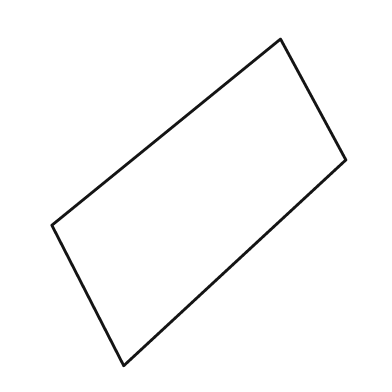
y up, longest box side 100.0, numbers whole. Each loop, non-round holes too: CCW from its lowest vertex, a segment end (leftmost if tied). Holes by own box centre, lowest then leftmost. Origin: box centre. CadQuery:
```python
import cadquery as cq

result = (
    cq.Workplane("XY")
    .moveTo(-23.0, -50.0)
    .lineTo(45.0, 13.0)
    .lineTo(25.0, 50.0)
    .lineTo(-45.0, -7.0)
    .close()
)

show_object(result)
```